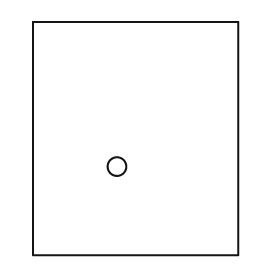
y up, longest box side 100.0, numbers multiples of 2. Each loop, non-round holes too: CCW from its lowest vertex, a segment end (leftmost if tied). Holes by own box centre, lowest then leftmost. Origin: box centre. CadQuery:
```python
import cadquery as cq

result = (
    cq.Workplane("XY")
    .moveTo(-44.0, -50.0)
    .lineTo(44.0, -50.0)
    .lineTo(44.0, 50.0)
    .lineTo(-44.0, 50.0)
    .close()
    .moveTo(-8.0, -12.0)
    .circle(4.0)
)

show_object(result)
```